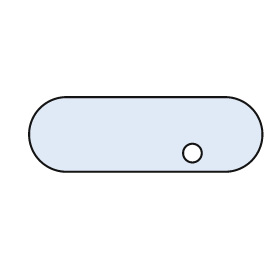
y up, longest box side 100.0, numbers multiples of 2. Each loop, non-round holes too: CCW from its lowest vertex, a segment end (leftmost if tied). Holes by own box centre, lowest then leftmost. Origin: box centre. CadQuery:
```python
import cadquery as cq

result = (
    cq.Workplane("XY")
    .moveTo(-34.0, -16.0)
    .lineTo(34.0, -16.0)
    .threePointArc((50.0, 0.0), (34.0, 16.0))
    .lineTo(-34.0, 16.0)
    .threePointArc((-50.0, 0.0), (-34.0, -16.0))
    .close()
    .moveTo(20.0, -8.0)
    .circle(4.0)
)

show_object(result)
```